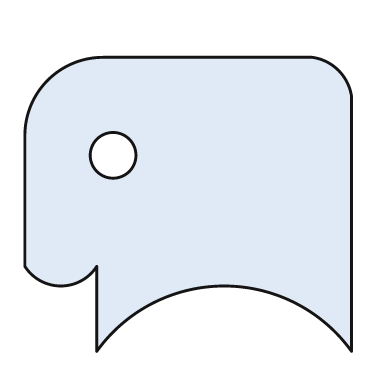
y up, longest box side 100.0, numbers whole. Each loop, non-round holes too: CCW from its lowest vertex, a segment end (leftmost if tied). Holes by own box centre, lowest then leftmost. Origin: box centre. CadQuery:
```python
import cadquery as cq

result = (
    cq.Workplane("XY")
    .moveTo(-28.0, -45.0)
    .threePointArc((11.0, -25.0), (50.0, -45.0))
    .lineTo(50.0, 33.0)
    .threePointArc((46.0, 41.0), (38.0, 45.0))
    .lineTo(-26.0, 45.0)
    .threePointArc((-43.0, 38.0), (-50.0, 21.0))
    .lineTo(-50.0, -19.0)
    .threePointArc((-39.0, -25.0), (-28.0, -19.0))
    .close()
    .moveTo(-23.0, 15.0)
    .circle(7.0)
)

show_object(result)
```